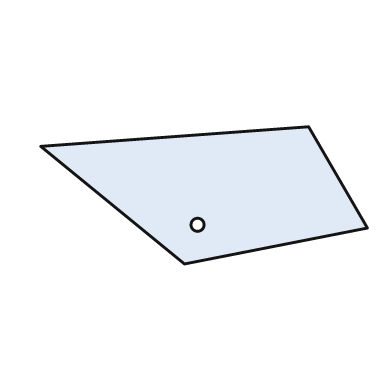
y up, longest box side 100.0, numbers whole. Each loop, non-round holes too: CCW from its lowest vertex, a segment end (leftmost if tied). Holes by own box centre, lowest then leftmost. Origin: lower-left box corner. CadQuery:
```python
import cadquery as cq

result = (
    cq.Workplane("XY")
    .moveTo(44.0, 0.0)
    .lineTo(100.0, 11.0)
    .lineTo(82.0, 42.0)
    .lineTo(0.0, 36.0)
    .close()
    .moveTo(48.0, 12.0)
    .circle(2.0)
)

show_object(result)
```